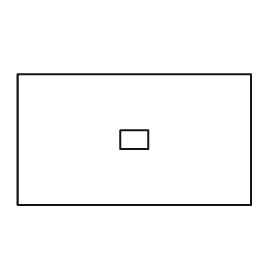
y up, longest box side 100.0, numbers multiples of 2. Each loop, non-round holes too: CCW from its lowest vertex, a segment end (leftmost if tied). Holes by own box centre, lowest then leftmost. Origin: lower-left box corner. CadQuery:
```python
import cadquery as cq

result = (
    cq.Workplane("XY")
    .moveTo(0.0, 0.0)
    .lineTo(100.0, 0.0)
    .lineTo(100.0, 56.0)
    .lineTo(0.0, 56.0)
    .close()
    .moveTo(44.0, 24.0)
    .lineTo(56.0, 24.0)
    .lineTo(56.0, 32.0)
    .lineTo(44.0, 32.0)
    .close()
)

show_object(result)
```